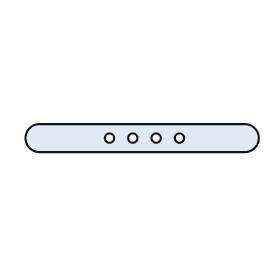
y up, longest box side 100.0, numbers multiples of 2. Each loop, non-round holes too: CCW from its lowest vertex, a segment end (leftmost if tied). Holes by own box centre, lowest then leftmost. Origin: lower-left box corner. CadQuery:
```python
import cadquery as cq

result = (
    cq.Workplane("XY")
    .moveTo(6.0, 0.0)
    .lineTo(94.0, 0.0)
    .threePointArc((100.0, 6.0), (94.0, 12.0))
    .lineTo(6.0, 12.0)
    .threePointArc((0.0, 6.0), (6.0, 0.0))
    .close()
    .moveTo(36.0, 6.0)
    .circle(2.0)
    .moveTo(46.0, 6.0)
    .circle(2.0)
    .moveTo(56.0, 6.0)
    .circle(2.0)
    .moveTo(66.0, 6.0)
    .circle(2.0)
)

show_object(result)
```